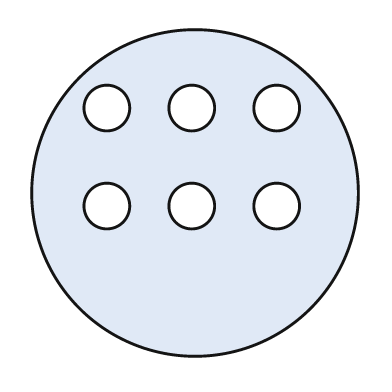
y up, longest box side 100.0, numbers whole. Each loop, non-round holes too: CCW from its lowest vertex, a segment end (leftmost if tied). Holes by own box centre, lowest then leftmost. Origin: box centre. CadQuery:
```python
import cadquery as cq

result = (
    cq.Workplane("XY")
    .moveTo(0.0, 0.0)
    .circle(50.0)
    .moveTo(-27.0, -4.0)
    .circle(7.0)
    .moveTo(-1.0, -4.0)
    .circle(7.0)
    .moveTo(25.0, -4.0)
    .circle(7.0)
    .moveTo(-27.0, 26.0)
    .circle(7.0)
    .moveTo(-1.0, 26.0)
    .circle(7.0)
    .moveTo(25.0, 26.0)
    .circle(7.0)
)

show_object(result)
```